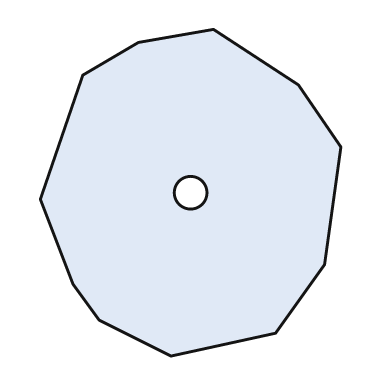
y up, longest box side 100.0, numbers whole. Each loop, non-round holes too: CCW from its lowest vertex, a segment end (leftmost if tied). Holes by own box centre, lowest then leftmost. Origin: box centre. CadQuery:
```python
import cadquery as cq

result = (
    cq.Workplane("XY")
    .moveTo(-6.0, -50.0)
    .lineTo(26.0, -43.0)
    .lineTo(41.0, -22.0)
    .lineTo(46.0, 14.0)
    .lineTo(33.0, 33.0)
    .lineTo(7.0, 50.0)
    .lineTo(-16.0, 46.0)
    .lineTo(-33.0, 36.0)
    .lineTo(-46.0, -2.0)
    .lineTo(-36.0, -28.0)
    .lineTo(-28.0, -39.0)
    .close()
    .moveTo(0.0, 0.0)
    .circle(5.0)
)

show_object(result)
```